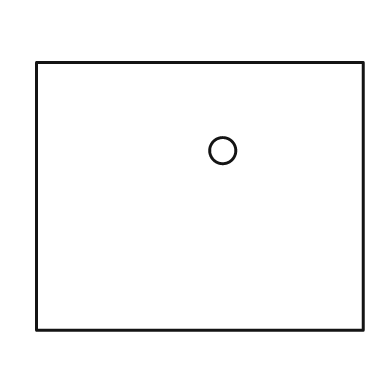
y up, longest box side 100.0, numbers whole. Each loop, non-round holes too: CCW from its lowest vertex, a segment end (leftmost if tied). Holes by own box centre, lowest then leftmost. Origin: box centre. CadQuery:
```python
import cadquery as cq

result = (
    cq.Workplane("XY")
    .moveTo(-50.0, -41.0)
    .lineTo(50.0, -41.0)
    .lineTo(50.0, 41.0)
    .lineTo(-50.0, 41.0)
    .close()
    .moveTo(7.0, 14.0)
    .circle(4.0)
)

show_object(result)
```